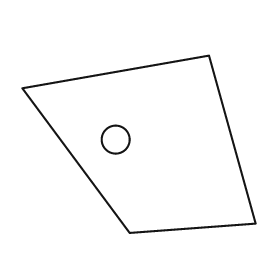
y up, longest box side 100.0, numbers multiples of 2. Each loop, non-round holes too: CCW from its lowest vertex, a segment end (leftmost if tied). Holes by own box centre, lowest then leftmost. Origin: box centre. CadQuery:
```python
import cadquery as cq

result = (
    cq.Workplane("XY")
    .moveTo(-4.0, -38.0)
    .lineTo(50.0, -34.0)
    .lineTo(30.0, 38.0)
    .lineTo(-50.0, 24.0)
    .close()
    .moveTo(-10.0, 2.0)
    .circle(6.0)
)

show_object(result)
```